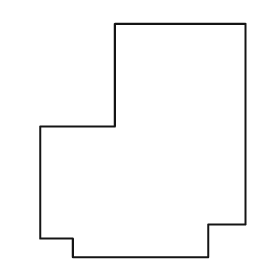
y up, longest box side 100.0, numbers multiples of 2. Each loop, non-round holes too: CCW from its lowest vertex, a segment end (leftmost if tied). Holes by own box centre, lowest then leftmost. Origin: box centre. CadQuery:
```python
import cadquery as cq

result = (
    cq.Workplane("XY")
    .moveTo(-30.0, -50.0)
    .lineTo(28.0, -50.0)
    .lineTo(28.0, -36.0)
    .lineTo(44.0, -36.0)
    .lineTo(44.0, 50.0)
    .lineTo(-12.0, 50.0)
    .lineTo(-12.0, 6.0)
    .lineTo(-44.0, 6.0)
    .lineTo(-44.0, -42.0)
    .lineTo(-30.0, -42.0)
    .close()
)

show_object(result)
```